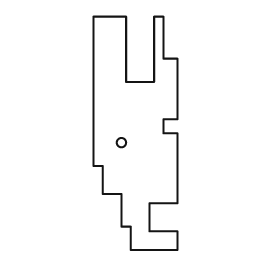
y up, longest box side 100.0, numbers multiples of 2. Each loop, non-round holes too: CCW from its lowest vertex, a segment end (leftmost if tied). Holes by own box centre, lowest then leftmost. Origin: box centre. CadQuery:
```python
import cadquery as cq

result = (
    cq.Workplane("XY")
    .moveTo(-2.0, -50.0)
    .lineTo(18.0, -50.0)
    .lineTo(18.0, -42.0)
    .lineTo(6.0, -42.0)
    .lineTo(6.0, -30.0)
    .lineTo(18.0, -30.0)
    .lineTo(18.0, 0.0)
    .lineTo(12.0, 0.0)
    .lineTo(12.0, 6.0)
    .lineTo(18.0, 6.0)
    .lineTo(18.0, 32.0)
    .lineTo(12.0, 32.0)
    .lineTo(12.0, 50.0)
    .lineTo(8.0, 50.0)
    .lineTo(8.0, 22.0)
    .lineTo(-4.0, 22.0)
    .lineTo(-4.0, 50.0)
    .lineTo(-18.0, 50.0)
    .lineTo(-18.0, -14.0)
    .lineTo(-14.0, -14.0)
    .lineTo(-14.0, -26.0)
    .lineTo(-6.0, -26.0)
    .lineTo(-6.0, -40.0)
    .lineTo(-2.0, -40.0)
    .close()
    .moveTo(-6.0, -4.0)
    .circle(2.0)
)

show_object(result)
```